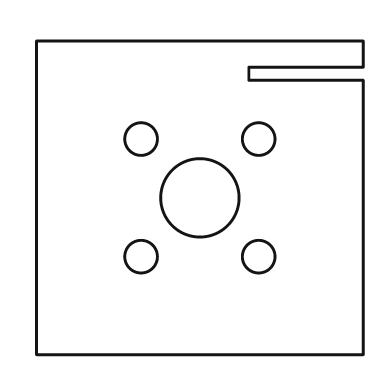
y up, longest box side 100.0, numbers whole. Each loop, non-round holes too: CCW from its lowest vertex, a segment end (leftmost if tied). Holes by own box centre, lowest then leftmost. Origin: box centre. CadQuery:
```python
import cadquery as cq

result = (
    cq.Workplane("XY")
    .moveTo(-50.0, -48.0)
    .lineTo(50.0, -48.0)
    .lineTo(50.0, 36.0)
    .lineTo(15.0, 36.0)
    .lineTo(15.0, 40.0)
    .lineTo(50.0, 40.0)
    .lineTo(50.0, 48.0)
    .lineTo(-50.0, 48.0)
    .close()
    .moveTo(-18.0, -18.0)
    .circle(5.0)
    .moveTo(18.0, -18.0)
    .circle(5.0)
    .moveTo(0.0, 0.0)
    .circle(12.0)
    .moveTo(-18.0, 18.0)
    .circle(5.0)
    .moveTo(18.0, 18.0)
    .circle(5.0)
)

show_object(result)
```